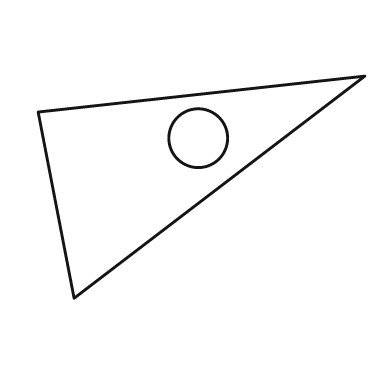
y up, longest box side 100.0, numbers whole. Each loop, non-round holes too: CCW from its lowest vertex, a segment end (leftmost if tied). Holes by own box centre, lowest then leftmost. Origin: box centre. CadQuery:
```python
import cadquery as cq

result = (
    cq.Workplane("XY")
    .moveTo(-39.0, -34.0)
    .lineTo(50.0, 34.0)
    .lineTo(-50.0, 23.0)
    .close()
    .moveTo(-1.0, 15.0)
    .circle(9.0)
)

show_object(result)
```